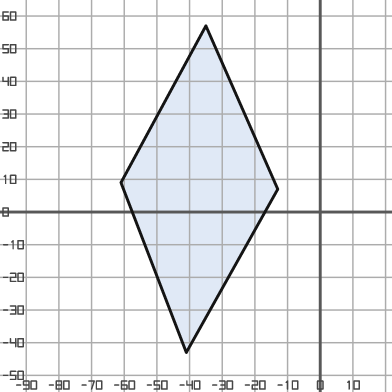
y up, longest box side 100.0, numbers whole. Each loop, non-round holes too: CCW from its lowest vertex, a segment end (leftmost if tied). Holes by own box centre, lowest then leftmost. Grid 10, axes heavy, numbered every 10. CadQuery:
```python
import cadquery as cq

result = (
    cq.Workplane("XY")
    .moveTo(-41.0, -43.0)
    .lineTo(-13.0, 7.0)
    .lineTo(-35.0, 57.0)
    .lineTo(-61.0, 9.0)
    .close()
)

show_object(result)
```